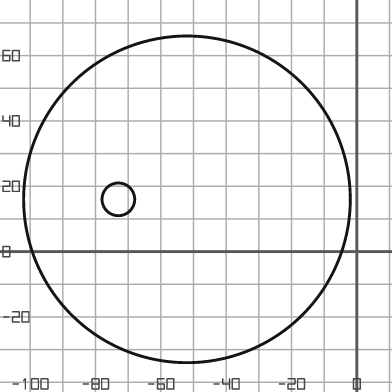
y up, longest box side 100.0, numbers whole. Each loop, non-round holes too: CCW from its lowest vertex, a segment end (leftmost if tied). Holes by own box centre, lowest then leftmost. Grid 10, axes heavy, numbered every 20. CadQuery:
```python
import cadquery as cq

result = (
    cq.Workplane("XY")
    .moveTo(-52.0, 16.0)
    .circle(50.0)
    .moveTo(-73.0, 16.0)
    .circle(5.0)
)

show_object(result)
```